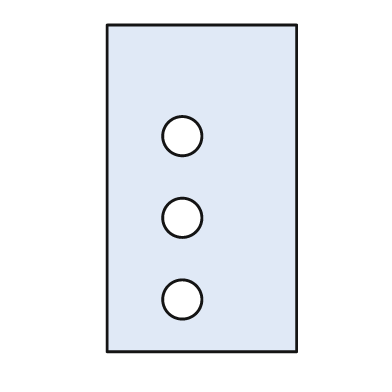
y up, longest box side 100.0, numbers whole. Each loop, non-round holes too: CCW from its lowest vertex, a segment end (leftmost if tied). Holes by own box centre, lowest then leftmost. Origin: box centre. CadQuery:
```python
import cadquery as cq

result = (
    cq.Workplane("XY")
    .moveTo(-29.0, -50.0)
    .lineTo(29.0, -50.0)
    .lineTo(29.0, 50.0)
    .lineTo(-29.0, 50.0)
    .close()
    .moveTo(-6.0, -34.0)
    .circle(6.0)
    .moveTo(-6.0, -9.0)
    .circle(6.0)
    .moveTo(-6.0, 16.0)
    .circle(6.0)
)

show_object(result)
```